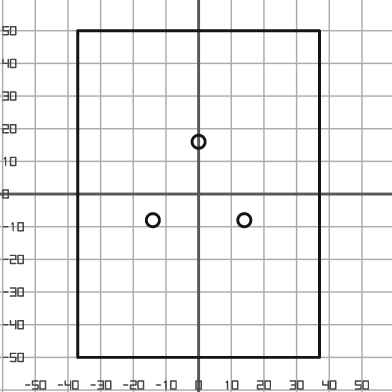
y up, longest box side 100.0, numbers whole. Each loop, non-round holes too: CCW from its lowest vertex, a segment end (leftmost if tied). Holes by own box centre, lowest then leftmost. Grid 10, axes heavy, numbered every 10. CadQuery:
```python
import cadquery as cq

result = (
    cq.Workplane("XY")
    .moveTo(-37.0, -50.0)
    .lineTo(37.0, -50.0)
    .lineTo(37.0, 50.0)
    .lineTo(-37.0, 50.0)
    .close()
    .moveTo(-14.0, -8.0)
    .circle(2.0)
    .moveTo(14.0, -8.0)
    .circle(2.0)
    .moveTo(0.0, 16.0)
    .circle(2.0)
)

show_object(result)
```